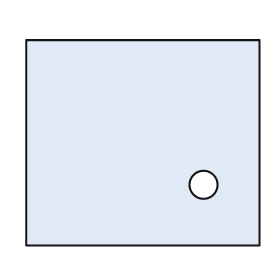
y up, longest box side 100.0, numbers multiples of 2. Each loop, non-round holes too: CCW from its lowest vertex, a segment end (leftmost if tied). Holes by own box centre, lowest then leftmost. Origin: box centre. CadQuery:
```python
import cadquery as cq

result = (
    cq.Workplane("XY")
    .moveTo(-50.0, -44.0)
    .lineTo(50.0, -44.0)
    .lineTo(50.0, 44.0)
    .lineTo(-50.0, 44.0)
    .close()
    .moveTo(26.0, -18.0)
    .circle(6.0)
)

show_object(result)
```